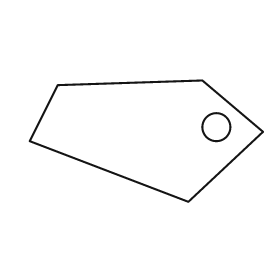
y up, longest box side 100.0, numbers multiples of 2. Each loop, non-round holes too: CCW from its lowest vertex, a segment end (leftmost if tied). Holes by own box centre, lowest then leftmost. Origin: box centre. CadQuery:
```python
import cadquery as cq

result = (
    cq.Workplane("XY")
    .moveTo(18.0, -26.0)
    .lineTo(50.0, 4.0)
    .lineTo(24.0, 26.0)
    .lineTo(-38.0, 24.0)
    .lineTo(-50.0, 0.0)
    .close()
    .moveTo(30.0, 6.0)
    .circle(6.0)
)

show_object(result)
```